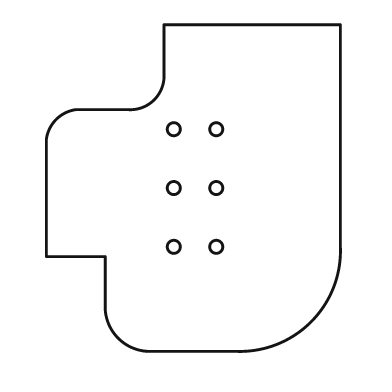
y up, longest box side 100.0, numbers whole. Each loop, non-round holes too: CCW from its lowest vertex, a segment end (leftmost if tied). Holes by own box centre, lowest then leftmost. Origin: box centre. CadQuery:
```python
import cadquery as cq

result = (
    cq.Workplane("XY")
    .moveTo(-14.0, -50.0)
    .lineTo(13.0, -50.0)
    .threePointArc((36.0, -41.0), (45.0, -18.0))
    .lineTo(45.0, 50.0)
    .lineTo(-9.0, 50.0)
    .lineTo(-9.0, 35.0)
    .threePointArc((-12.0, 27.0), (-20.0, 24.0))
    .lineTo(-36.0, 24.0)
    .threePointArc((-42.0, 21.0), (-45.0, 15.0))
    .lineTo(-45.0, -21.0)
    .lineTo(-27.0, -21.0)
    .lineTo(-27.0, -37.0)
    .threePointArc((-23.0, -46.0), (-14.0, -50.0))
    .close()
    .moveTo(-6.0, -18.0)
    .circle(2.0)
    .moveTo(7.0, -18.0)
    .circle(2.0)
    .moveTo(-6.0, 0.0)
    .circle(2.0)
    .moveTo(7.0, 0.0)
    .circle(2.0)
    .moveTo(-6.0, 18.0)
    .circle(2.0)
    .moveTo(7.0, 18.0)
    .circle(2.0)
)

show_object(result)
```